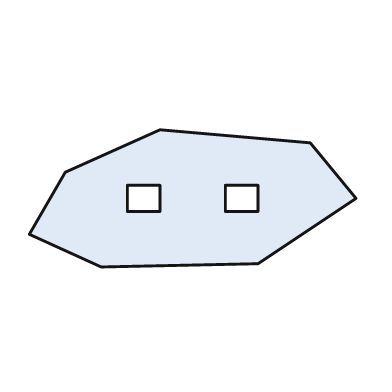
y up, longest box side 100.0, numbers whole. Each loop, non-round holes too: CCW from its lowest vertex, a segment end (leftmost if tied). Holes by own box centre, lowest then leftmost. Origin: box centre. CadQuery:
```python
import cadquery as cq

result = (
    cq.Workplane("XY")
    .moveTo(-28.0, -21.0)
    .lineTo(20.0, -20.0)
    .lineTo(50.0, 0.0)
    .lineTo(36.0, 17.0)
    .lineTo(-10.0, 21.0)
    .lineTo(-39.0, 8.0)
    .lineTo(-50.0, -11.0)
    .close()
    .moveTo(-20.0, -4.0)
    .lineTo(-10.0, -4.0)
    .lineTo(-10.0, 4.0)
    .lineTo(-20.0, 4.0)
    .close()
    .moveTo(10.0, -4.0)
    .lineTo(20.0, -4.0)
    .lineTo(20.0, 4.0)
    .lineTo(10.0, 4.0)
    .close()
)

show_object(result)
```